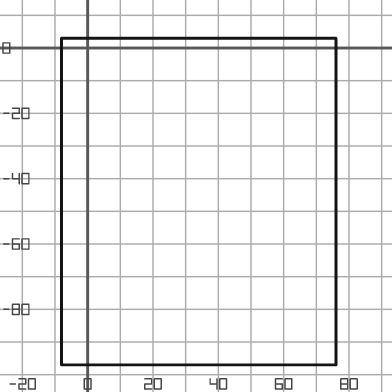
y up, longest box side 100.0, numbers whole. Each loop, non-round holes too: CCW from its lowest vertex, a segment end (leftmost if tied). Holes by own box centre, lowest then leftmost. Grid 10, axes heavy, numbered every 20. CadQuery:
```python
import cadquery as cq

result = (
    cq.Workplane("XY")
    .moveTo(-8.0, -97.0)
    .lineTo(76.0, -97.0)
    .lineTo(76.0, 3.0)
    .lineTo(-8.0, 3.0)
    .close()
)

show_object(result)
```